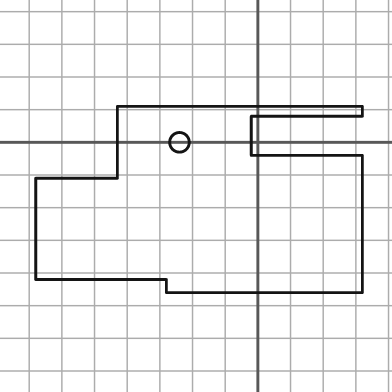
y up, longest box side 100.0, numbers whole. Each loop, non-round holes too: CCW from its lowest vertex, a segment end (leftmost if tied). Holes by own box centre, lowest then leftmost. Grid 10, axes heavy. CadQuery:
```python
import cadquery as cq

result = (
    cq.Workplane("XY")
    .moveTo(-28.0, -46.0)
    .lineTo(32.0, -46.0)
    .lineTo(32.0, -4.0)
    .lineTo(-2.0, -4.0)
    .lineTo(-2.0, 8.0)
    .lineTo(32.0, 8.0)
    .lineTo(32.0, 11.0)
    .lineTo(-43.0, 11.0)
    .lineTo(-43.0, -11.0)
    .lineTo(-68.0, -11.0)
    .lineTo(-68.0, -42.0)
    .lineTo(-28.0, -42.0)
    .close()
    .moveTo(-24.0, 0.0)
    .circle(3.0)
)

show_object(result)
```